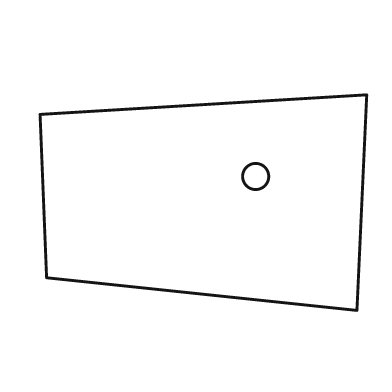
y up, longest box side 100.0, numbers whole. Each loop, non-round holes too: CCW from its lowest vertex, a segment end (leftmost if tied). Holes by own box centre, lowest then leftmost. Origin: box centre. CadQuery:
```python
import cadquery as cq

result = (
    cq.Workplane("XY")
    .moveTo(47.0, -33.0)
    .lineTo(50.0, 33.0)
    .lineTo(-50.0, 27.0)
    .lineTo(-48.0, -23.0)
    .close()
    .moveTo(16.0, 8.0)
    .circle(4.0)
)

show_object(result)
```